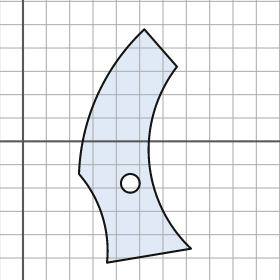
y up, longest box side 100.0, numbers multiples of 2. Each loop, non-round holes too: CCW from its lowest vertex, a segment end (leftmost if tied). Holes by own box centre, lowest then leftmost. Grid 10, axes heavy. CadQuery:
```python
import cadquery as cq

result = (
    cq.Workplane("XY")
    .moveTo(36.0, -52.0)
    .lineTo(72.0, -46.0)
    .threePointArc((54.0, -8.0), (66.0, 32.0))
    .lineTo(52.0, 48.0)
    .threePointArc((32.0, 20.0), (24.0, -14.0))
    .threePointArc((34.0, -32.0), (36.0, -52.0))
    .close()
    .moveTo(46.0, -18.0)
    .circle(4.0)
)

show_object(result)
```